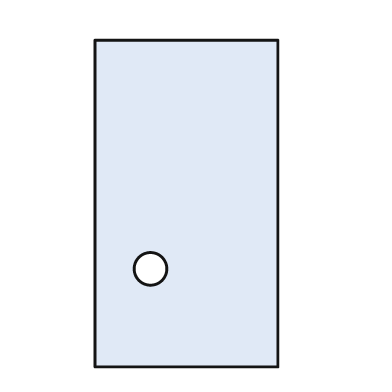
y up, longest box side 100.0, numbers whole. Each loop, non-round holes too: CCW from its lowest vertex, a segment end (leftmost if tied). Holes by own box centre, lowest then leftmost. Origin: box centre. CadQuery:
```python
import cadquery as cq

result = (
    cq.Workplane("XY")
    .moveTo(-28.0, -50.0)
    .lineTo(28.0, -50.0)
    .lineTo(28.0, 50.0)
    .lineTo(-28.0, 50.0)
    .close()
    .moveTo(-11.0, -20.0)
    .circle(5.0)
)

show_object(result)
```